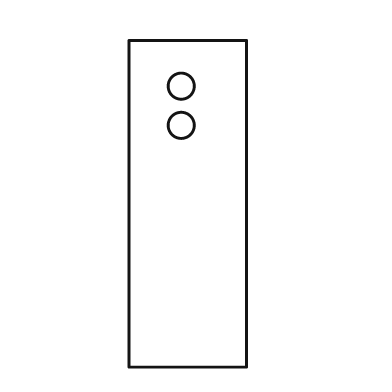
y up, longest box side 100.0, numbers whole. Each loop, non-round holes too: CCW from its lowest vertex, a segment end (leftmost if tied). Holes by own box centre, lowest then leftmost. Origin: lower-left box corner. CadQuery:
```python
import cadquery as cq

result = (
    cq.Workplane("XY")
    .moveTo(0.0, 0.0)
    .lineTo(36.0, 0.0)
    .lineTo(36.0, 100.0)
    .lineTo(0.0, 100.0)
    .close()
    .moveTo(16.0, 74.0)
    .circle(4.0)
    .moveTo(16.0, 86.0)
    .circle(4.0)
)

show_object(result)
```